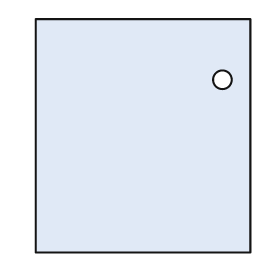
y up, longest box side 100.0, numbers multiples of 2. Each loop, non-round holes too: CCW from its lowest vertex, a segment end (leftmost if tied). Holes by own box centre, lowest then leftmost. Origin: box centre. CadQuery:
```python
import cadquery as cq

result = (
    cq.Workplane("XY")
    .moveTo(-46.0, -50.0)
    .lineTo(46.0, -50.0)
    .lineTo(46.0, 50.0)
    .lineTo(-46.0, 50.0)
    .close()
    .moveTo(34.0, 24.0)
    .circle(4.0)
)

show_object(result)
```